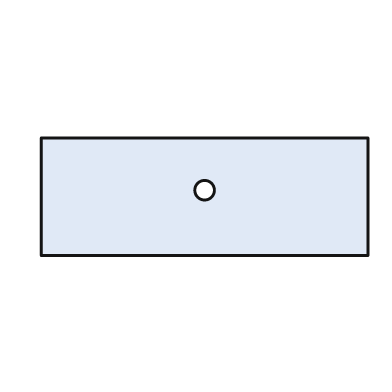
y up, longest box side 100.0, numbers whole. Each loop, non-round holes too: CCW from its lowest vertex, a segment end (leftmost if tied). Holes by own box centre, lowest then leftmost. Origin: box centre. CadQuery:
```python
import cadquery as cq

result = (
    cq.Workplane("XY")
    .moveTo(-50.0, -18.0)
    .lineTo(50.0, -18.0)
    .lineTo(50.0, 18.0)
    .lineTo(-50.0, 18.0)
    .close()
    .moveTo(0.0, 2.0)
    .circle(3.0)
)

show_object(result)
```